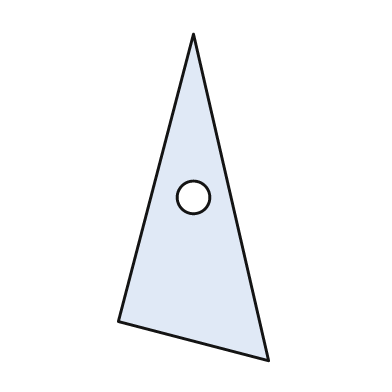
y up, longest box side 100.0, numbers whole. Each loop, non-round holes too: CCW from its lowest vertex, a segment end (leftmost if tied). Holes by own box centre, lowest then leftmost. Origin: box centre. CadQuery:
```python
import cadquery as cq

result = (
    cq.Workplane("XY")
    .moveTo(23.0, -50.0)
    .lineTo(0.0, 50.0)
    .lineTo(-23.0, -38.0)
    .close()
    .moveTo(0.0, 0.0)
    .circle(5.0)
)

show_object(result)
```